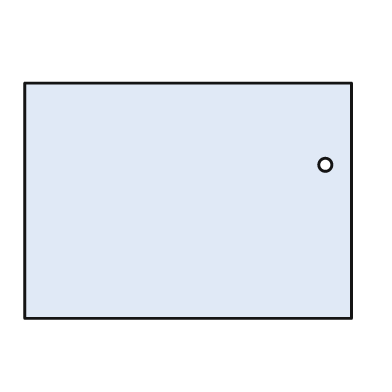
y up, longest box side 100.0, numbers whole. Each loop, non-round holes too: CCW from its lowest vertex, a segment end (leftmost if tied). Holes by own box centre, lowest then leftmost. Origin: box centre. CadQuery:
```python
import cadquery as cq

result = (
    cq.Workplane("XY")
    .moveTo(-50.0, -36.0)
    .lineTo(50.0, -36.0)
    .lineTo(50.0, 36.0)
    .lineTo(-50.0, 36.0)
    .close()
    .moveTo(42.0, 11.0)
    .circle(2.0)
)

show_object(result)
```